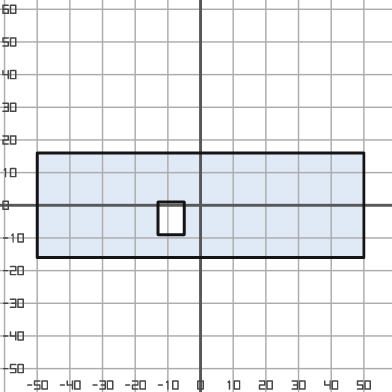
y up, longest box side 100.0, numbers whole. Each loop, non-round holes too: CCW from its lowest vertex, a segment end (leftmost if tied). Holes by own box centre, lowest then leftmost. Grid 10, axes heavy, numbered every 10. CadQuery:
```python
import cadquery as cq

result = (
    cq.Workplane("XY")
    .moveTo(-50.0, -16.0)
    .lineTo(50.0, -16.0)
    .lineTo(50.0, 16.0)
    .lineTo(-50.0, 16.0)
    .close()
    .moveTo(-13.0, -9.0)
    .lineTo(-5.0, -9.0)
    .lineTo(-5.0, 1.0)
    .lineTo(-13.0, 1.0)
    .close()
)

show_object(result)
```